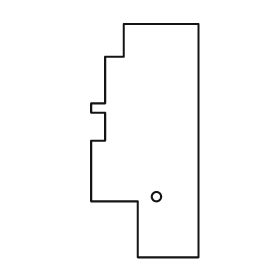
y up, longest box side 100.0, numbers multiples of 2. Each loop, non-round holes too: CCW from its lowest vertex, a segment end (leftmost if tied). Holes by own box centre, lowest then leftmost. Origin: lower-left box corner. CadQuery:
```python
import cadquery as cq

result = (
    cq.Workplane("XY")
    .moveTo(20.0, 0.0)
    .lineTo(46.0, 0.0)
    .lineTo(46.0, 100.0)
    .lineTo(14.0, 100.0)
    .lineTo(14.0, 86.0)
    .lineTo(6.0, 86.0)
    .lineTo(6.0, 66.0)
    .lineTo(0.0, 66.0)
    .lineTo(0.0, 62.0)
    .lineTo(6.0, 62.0)
    .lineTo(6.0, 50.0)
    .lineTo(0.0, 50.0)
    .lineTo(0.0, 24.0)
    .lineTo(20.0, 24.0)
    .close()
    .moveTo(28.0, 26.0)
    .circle(2.0)
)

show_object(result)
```